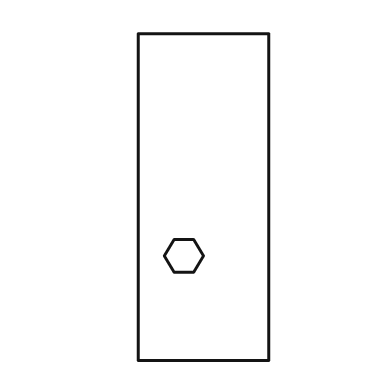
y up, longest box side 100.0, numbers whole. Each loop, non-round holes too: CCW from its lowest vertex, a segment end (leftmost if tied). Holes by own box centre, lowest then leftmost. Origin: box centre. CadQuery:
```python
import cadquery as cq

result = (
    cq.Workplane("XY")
    .moveTo(-20.0, -50.0)
    .lineTo(20.0, -50.0)
    .lineTo(20.0, 50.0)
    .lineTo(-20.0, 50.0)
    .close()
    .moveTo(-9.0, -23.0)
    .lineTo(-3.0, -23.0)
    .lineTo(0.0, -18.0)
    .lineTo(-3.0, -13.0)
    .lineTo(-9.0, -13.0)
    .lineTo(-12.0, -18.0)
    .close()
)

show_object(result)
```